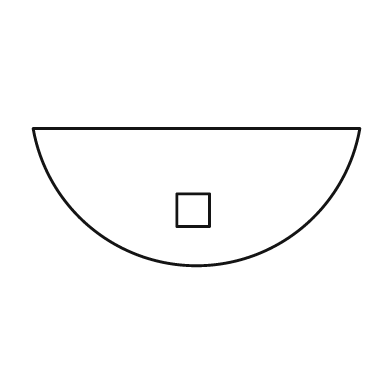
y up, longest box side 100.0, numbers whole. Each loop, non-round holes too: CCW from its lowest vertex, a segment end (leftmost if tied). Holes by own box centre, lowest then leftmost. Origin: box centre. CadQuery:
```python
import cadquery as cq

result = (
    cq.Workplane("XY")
    .moveTo(-50.0, 21.0)
    .threePointArc((0.0, -21.0), (50.0, 21.0))
    .close()
    .moveTo(-6.0, -9.0)
    .lineTo(4.0, -9.0)
    .lineTo(4.0, 1.0)
    .lineTo(-6.0, 1.0)
    .close()
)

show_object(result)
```